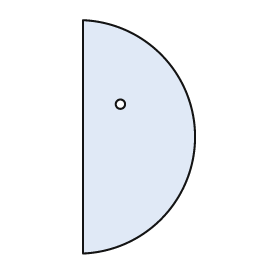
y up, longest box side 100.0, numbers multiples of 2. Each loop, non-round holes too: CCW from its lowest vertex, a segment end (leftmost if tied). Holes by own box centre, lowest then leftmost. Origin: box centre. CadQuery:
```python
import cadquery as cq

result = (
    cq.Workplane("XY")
    .moveTo(-24.0, -50.0)
    .threePointArc((24.0, 0.0), (-24.0, 50.0))
    .close()
    .moveTo(-8.0, 14.0)
    .circle(2.0)
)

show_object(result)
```